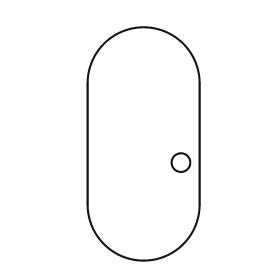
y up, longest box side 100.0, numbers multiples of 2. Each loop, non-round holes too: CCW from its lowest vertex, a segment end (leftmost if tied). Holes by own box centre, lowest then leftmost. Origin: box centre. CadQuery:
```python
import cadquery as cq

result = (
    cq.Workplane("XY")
    .moveTo(-24.0, -26.0)
    .threePointArc((0.0, -50.0), (24.0, -26.0))
    .lineTo(24.0, 26.0)
    .threePointArc((0.0, 50.0), (-24.0, 26.0))
    .close()
    .moveTo(16.0, -8.0)
    .circle(4.0)
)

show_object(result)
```